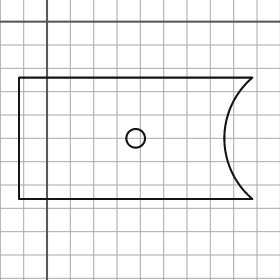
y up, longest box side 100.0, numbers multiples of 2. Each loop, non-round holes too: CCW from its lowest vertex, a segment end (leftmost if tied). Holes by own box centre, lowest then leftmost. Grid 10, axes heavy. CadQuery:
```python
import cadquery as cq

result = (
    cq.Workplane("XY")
    .moveTo(-12.0, -76.0)
    .lineTo(88.0, -76.0)
    .threePointArc((76.0, -50.0), (88.0, -24.0))
    .lineTo(-12.0, -24.0)
    .close()
    .moveTo(38.0, -50.0)
    .circle(4.0)
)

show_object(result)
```